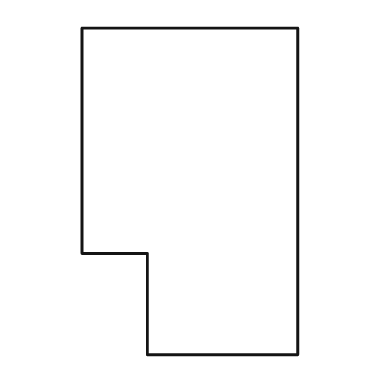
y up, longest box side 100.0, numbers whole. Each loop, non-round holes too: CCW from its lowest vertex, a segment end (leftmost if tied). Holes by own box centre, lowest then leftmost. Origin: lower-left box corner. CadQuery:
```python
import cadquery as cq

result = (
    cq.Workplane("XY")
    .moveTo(20.0, 0.0)
    .lineTo(66.0, 0.0)
    .lineTo(66.0, 100.0)
    .lineTo(0.0, 100.0)
    .lineTo(0.0, 31.0)
    .lineTo(20.0, 31.0)
    .close()
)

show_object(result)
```